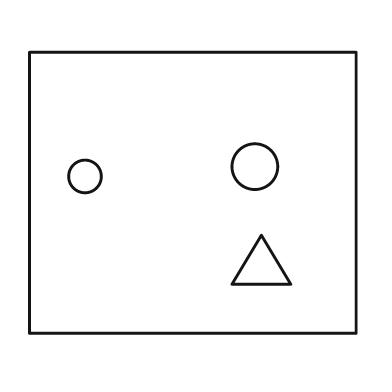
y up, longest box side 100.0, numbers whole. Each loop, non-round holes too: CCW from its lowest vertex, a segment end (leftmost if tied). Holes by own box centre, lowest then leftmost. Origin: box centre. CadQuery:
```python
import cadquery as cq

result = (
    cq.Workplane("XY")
    .moveTo(-50.0, -43.0)
    .lineTo(50.0, -43.0)
    .lineTo(50.0, 43.0)
    .lineTo(-50.0, 43.0)
    .close()
    .moveTo(12.0, -28.0)
    .lineTo(30.0, -28.0)
    .lineTo(21.0, -13.0)
    .close()
    .moveTo(-33.0, 5.0)
    .circle(5.0)
    .moveTo(19.0, 8.0)
    .circle(7.0)
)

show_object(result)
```